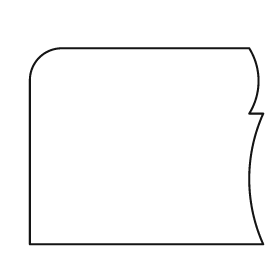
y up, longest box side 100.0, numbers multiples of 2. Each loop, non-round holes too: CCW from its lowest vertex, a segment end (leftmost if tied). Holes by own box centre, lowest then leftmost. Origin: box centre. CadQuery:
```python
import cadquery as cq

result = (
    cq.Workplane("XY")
    .moveTo(-50.0, -42.0)
    .lineTo(50.0, -42.0)
    .threePointArc((44.0, -14.0), (50.0, 14.0))
    .lineTo(44.0, 14.0)
    .threePointArc((48.0, 28.0), (44.0, 42.0))
    .lineTo(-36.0, 42.0)
    .threePointArc((-46.0, 38.0), (-50.0, 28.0))
    .close()
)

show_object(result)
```